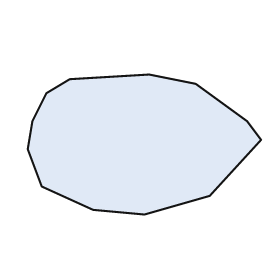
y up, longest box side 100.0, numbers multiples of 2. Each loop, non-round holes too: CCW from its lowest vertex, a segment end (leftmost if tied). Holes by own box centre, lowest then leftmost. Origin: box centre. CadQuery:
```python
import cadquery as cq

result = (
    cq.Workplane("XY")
    .moveTo(0.0, -30.0)
    .lineTo(28.0, -22.0)
    .lineTo(50.0, 2.0)
    .lineTo(44.0, 10.0)
    .lineTo(22.0, 26.0)
    .lineTo(2.0, 30.0)
    .lineTo(-32.0, 28.0)
    .lineTo(-42.0, 22.0)
    .lineTo(-48.0, 10.0)
    .lineTo(-50.0, -2.0)
    .lineTo(-44.0, -18.0)
    .lineTo(-22.0, -28.0)
    .close()
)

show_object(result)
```